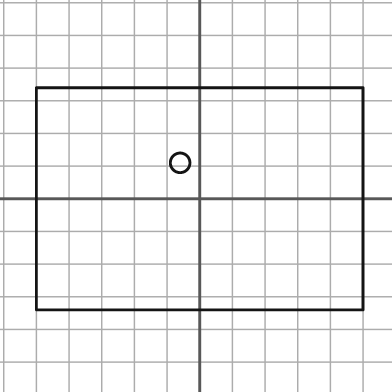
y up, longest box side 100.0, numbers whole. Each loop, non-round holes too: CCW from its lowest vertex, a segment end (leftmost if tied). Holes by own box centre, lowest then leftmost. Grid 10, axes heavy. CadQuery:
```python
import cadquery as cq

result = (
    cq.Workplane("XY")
    .moveTo(-50.0, -34.0)
    .lineTo(50.0, -34.0)
    .lineTo(50.0, 34.0)
    .lineTo(-50.0, 34.0)
    .close()
    .moveTo(-6.0, 11.0)
    .circle(3.0)
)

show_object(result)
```